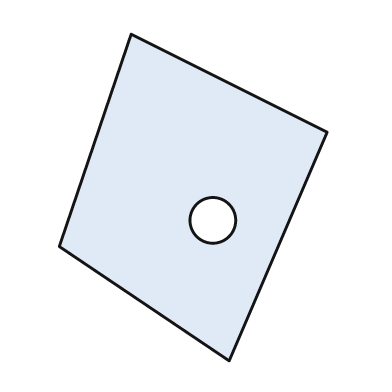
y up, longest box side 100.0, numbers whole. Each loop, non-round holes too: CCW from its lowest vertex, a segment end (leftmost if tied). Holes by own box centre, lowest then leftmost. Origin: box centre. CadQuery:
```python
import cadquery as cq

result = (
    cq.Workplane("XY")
    .moveTo(11.0, -50.0)
    .lineTo(41.0, 20.0)
    .lineTo(-19.0, 50.0)
    .lineTo(-41.0, -15.0)
    .close()
    .moveTo(6.0, -7.0)
    .circle(7.0)
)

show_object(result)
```